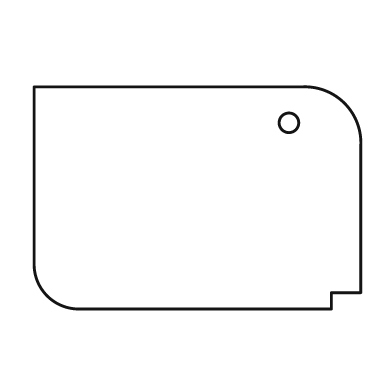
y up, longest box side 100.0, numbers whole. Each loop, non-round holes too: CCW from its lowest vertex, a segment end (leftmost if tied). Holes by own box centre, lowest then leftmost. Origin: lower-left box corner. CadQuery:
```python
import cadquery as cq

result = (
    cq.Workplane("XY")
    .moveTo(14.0, 0.0)
    .lineTo(91.0, 0.0)
    .lineTo(91.0, 5.0)
    .lineTo(100.0, 5.0)
    .lineTo(100.0, 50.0)
    .threePointArc((95.0, 63.0), (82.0, 68.0))
    .lineTo(0.0, 68.0)
    .lineTo(0.0, 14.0)
    .threePointArc((4.0, 4.0), (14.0, 0.0))
    .close()
    .moveTo(78.0, 57.0)
    .circle(3.0)
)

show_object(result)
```